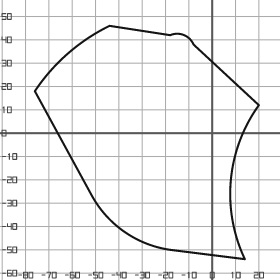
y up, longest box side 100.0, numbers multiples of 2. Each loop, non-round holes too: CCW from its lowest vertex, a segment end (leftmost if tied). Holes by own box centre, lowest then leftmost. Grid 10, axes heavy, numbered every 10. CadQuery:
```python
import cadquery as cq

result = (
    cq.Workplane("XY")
    .moveTo(14.0, -54.0)
    .threePointArc((8.0, -20.0), (20.0, 12.0))
    .lineTo(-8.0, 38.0)
    .threePointArc((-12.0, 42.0), (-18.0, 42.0))
    .lineTo(-44.0, 46.0)
    .threePointArc((-62.0, 34.0), (-76.0, 18.0))
    .lineTo(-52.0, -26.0)
    .threePointArc((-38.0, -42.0), (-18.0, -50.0))
    .close()
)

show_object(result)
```